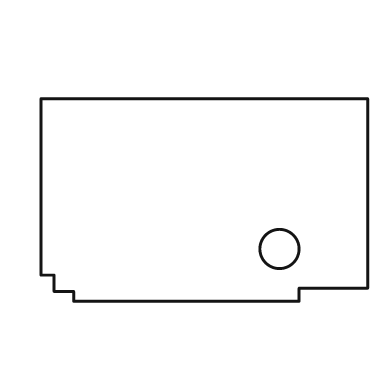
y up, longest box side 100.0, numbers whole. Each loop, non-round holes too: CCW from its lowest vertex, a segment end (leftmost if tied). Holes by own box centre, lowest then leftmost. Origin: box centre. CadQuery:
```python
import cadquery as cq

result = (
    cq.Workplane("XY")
    .moveTo(-40.0, -31.0)
    .lineTo(29.0, -31.0)
    .lineTo(29.0, -27.0)
    .lineTo(50.0, -27.0)
    .lineTo(50.0, 31.0)
    .lineTo(-50.0, 31.0)
    .lineTo(-50.0, -23.0)
    .lineTo(-46.0, -23.0)
    .lineTo(-46.0, -28.0)
    .lineTo(-40.0, -28.0)
    .close()
    .moveTo(23.0, -15.0)
    .circle(6.0)
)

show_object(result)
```